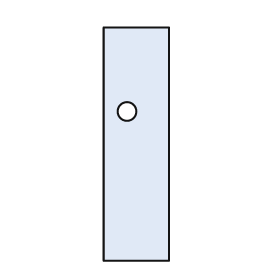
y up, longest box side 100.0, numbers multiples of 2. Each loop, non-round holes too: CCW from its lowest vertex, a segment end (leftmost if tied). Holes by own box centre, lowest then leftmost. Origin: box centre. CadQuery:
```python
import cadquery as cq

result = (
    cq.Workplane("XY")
    .moveTo(-14.0, -50.0)
    .lineTo(14.0, -50.0)
    .lineTo(14.0, 50.0)
    .lineTo(-14.0, 50.0)
    .close()
    .moveTo(-4.0, 14.0)
    .circle(4.0)
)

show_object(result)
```